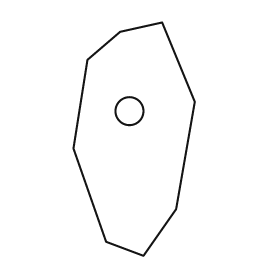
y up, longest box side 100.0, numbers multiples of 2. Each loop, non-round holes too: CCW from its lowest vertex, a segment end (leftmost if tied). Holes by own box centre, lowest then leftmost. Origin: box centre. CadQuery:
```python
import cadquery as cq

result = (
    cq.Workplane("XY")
    .moveTo(4.0, -50.0)
    .lineTo(18.0, -30.0)
    .lineTo(26.0, 16.0)
    .lineTo(12.0, 50.0)
    .lineTo(-6.0, 46.0)
    .lineTo(-20.0, 34.0)
    .lineTo(-26.0, -4.0)
    .lineTo(-12.0, -44.0)
    .close()
    .moveTo(-2.0, 12.0)
    .circle(6.0)
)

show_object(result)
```